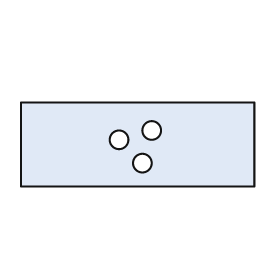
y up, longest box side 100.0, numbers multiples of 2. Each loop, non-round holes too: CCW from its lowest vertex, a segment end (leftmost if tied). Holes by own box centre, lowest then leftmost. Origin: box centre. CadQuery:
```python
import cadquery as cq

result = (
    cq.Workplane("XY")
    .moveTo(-50.0, -18.0)
    .lineTo(50.0, -18.0)
    .lineTo(50.0, 18.0)
    .lineTo(-50.0, 18.0)
    .close()
    .moveTo(2.0, -8.0)
    .circle(4.0)
    .moveTo(-8.0, 2.0)
    .circle(4.0)
    .moveTo(6.0, 6.0)
    .circle(4.0)
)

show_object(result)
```